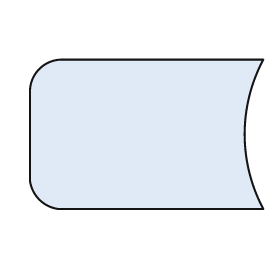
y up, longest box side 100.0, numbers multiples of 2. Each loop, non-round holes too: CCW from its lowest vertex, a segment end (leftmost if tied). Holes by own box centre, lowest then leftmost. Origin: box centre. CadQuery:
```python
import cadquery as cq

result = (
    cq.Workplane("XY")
    .moveTo(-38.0, -32.0)
    .lineTo(50.0, -32.0)
    .threePointArc((42.0, 0.0), (50.0, 32.0))
    .lineTo(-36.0, 32.0)
    .threePointArc((-46.0, 28.0), (-50.0, 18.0))
    .lineTo(-50.0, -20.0)
    .threePointArc((-46.0, -28.0), (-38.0, -32.0))
    .close()
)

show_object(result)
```